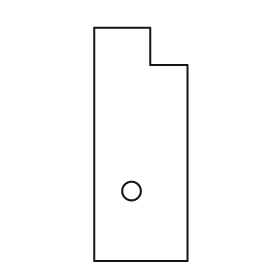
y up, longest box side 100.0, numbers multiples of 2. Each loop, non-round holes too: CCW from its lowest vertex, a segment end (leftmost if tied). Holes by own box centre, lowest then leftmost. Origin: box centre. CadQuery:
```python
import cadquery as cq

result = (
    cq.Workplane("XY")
    .moveTo(-20.0, -50.0)
    .lineTo(20.0, -50.0)
    .lineTo(20.0, 34.0)
    .lineTo(4.0, 34.0)
    .lineTo(4.0, 50.0)
    .lineTo(-20.0, 50.0)
    .close()
    .moveTo(-4.0, -20.0)
    .circle(4.0)
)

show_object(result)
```